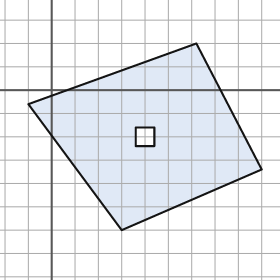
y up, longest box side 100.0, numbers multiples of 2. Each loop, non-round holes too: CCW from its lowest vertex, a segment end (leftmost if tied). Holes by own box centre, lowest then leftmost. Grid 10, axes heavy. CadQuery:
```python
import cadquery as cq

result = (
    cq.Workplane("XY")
    .moveTo(30.0, -60.0)
    .lineTo(90.0, -34.0)
    .lineTo(62.0, 20.0)
    .lineTo(-10.0, -6.0)
    .close()
    .moveTo(36.0, -24.0)
    .lineTo(44.0, -24.0)
    .lineTo(44.0, -16.0)
    .lineTo(36.0, -16.0)
    .close()
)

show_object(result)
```